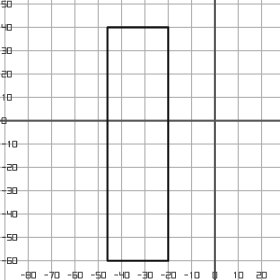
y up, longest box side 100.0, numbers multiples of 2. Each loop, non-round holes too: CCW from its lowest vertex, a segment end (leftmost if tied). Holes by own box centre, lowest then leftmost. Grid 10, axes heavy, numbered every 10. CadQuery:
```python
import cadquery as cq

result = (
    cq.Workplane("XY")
    .moveTo(-46.0, -60.0)
    .lineTo(-20.0, -60.0)
    .lineTo(-20.0, 40.0)
    .lineTo(-46.0, 40.0)
    .close()
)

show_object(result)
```